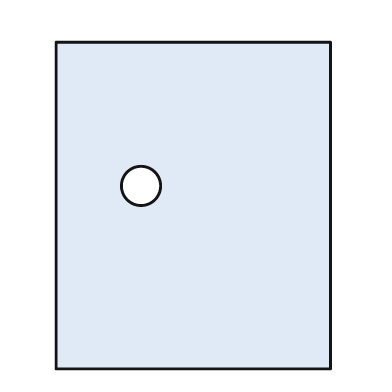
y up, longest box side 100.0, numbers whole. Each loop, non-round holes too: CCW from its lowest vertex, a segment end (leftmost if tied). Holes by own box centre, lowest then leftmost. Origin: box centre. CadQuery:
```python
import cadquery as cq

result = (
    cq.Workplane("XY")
    .moveTo(-42.0, -50.0)
    .lineTo(42.0, -50.0)
    .lineTo(42.0, 50.0)
    .lineTo(-42.0, 50.0)
    .close()
    .moveTo(-16.0, 6.0)
    .circle(6.0)
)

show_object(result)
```